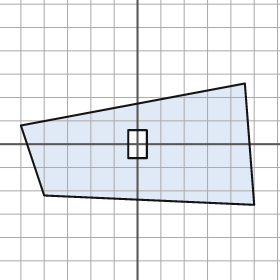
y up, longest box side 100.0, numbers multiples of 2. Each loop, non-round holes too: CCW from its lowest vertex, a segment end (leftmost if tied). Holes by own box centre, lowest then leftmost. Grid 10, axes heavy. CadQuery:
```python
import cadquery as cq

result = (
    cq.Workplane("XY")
    .moveTo(50.0, -26.0)
    .lineTo(46.0, 26.0)
    .lineTo(-50.0, 8.0)
    .lineTo(-40.0, -22.0)
    .close()
    .moveTo(-4.0, -6.0)
    .lineTo(4.0, -6.0)
    .lineTo(4.0, 6.0)
    .lineTo(-4.0, 6.0)
    .close()
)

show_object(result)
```